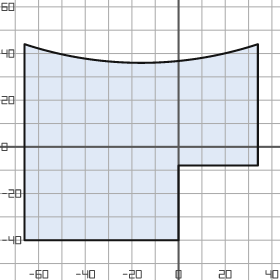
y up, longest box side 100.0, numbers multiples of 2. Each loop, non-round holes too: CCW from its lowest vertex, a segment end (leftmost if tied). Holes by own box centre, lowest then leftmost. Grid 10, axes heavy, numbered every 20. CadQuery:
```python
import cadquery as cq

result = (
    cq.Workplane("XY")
    .moveTo(-66.0, -40.0)
    .lineTo(0.0, -40.0)
    .lineTo(0.0, -8.0)
    .lineTo(34.0, -8.0)
    .lineTo(34.0, 44.0)
    .threePointArc((-16.0, 36.0), (-66.0, 44.0))
    .close()
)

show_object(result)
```